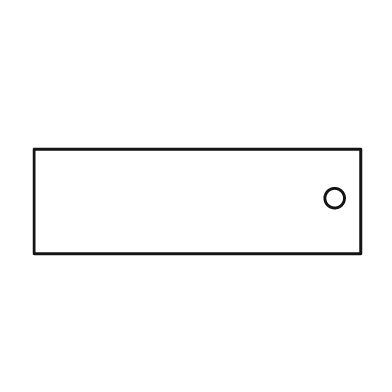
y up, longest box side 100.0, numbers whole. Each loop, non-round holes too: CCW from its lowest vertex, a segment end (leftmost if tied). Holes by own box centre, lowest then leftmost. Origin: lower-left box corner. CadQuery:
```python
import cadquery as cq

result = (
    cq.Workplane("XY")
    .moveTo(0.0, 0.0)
    .lineTo(100.0, 0.0)
    .lineTo(100.0, 32.0)
    .lineTo(0.0, 32.0)
    .close()
    .moveTo(92.0, 17.0)
    .circle(3.0)
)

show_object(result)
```